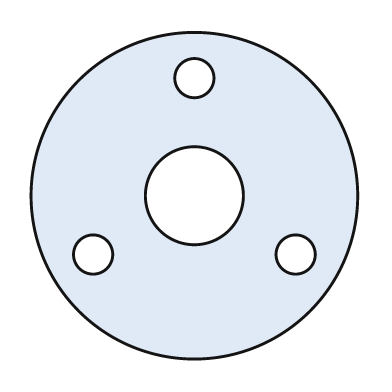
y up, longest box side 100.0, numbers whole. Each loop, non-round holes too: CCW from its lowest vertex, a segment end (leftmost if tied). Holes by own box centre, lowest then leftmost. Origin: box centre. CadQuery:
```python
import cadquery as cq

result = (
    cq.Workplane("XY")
    .moveTo(0.0, 0.0)
    .circle(50.0)
    .moveTo(-31.0, -18.0)
    .circle(6.0)
    .moveTo(31.0, -18.0)
    .circle(6.0)
    .moveTo(0.0, 0.0)
    .circle(15.0)
    .moveTo(0.0, 36.0)
    .circle(6.0)
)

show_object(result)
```